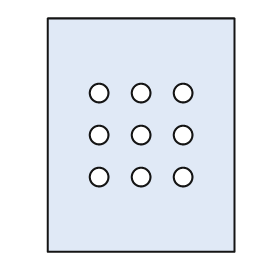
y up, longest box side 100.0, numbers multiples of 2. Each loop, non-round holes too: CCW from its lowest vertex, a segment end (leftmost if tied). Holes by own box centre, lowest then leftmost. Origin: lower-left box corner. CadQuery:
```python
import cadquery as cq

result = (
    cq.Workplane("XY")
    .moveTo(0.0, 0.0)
    .lineTo(80.0, 0.0)
    .lineTo(80.0, 100.0)
    .lineTo(0.0, 100.0)
    .close()
    .moveTo(22.0, 32.0)
    .circle(4.0)
    .moveTo(40.0, 32.0)
    .circle(4.0)
    .moveTo(58.0, 32.0)
    .circle(4.0)
    .moveTo(22.0, 50.0)
    .circle(4.0)
    .moveTo(40.0, 50.0)
    .circle(4.0)
    .moveTo(58.0, 50.0)
    .circle(4.0)
    .moveTo(22.0, 68.0)
    .circle(4.0)
    .moveTo(40.0, 68.0)
    .circle(4.0)
    .moveTo(58.0, 68.0)
    .circle(4.0)
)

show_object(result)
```